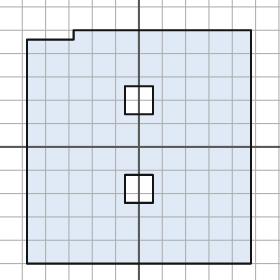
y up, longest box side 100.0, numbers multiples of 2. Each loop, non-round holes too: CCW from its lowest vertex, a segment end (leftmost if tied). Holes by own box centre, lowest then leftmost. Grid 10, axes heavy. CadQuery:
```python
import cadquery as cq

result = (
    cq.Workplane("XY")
    .moveTo(-48.0, -50.0)
    .lineTo(48.0, -50.0)
    .lineTo(48.0, 50.0)
    .lineTo(-28.0, 50.0)
    .lineTo(-28.0, 46.0)
    .lineTo(-48.0, 46.0)
    .close()
    .moveTo(-6.0, -24.0)
    .lineTo(6.0, -24.0)
    .lineTo(6.0, -12.0)
    .lineTo(-6.0, -12.0)
    .close()
    .moveTo(-6.0, 14.0)
    .lineTo(6.0, 14.0)
    .lineTo(6.0, 26.0)
    .lineTo(-6.0, 26.0)
    .close()
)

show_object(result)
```